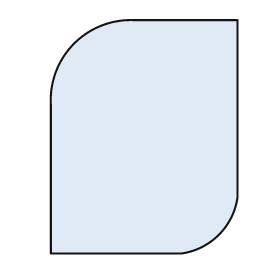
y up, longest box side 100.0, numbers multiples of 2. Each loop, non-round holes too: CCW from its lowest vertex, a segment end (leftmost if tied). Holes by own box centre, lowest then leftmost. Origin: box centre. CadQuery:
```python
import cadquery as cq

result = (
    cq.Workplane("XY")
    .moveTo(-40.0, -50.0)
    .lineTo(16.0, -50.0)
    .threePointArc((32.0, -42.0), (40.0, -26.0))
    .lineTo(40.0, 50.0)
    .lineTo(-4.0, 50.0)
    .threePointArc((-30.0, 40.0), (-40.0, 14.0))
    .close()
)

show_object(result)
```